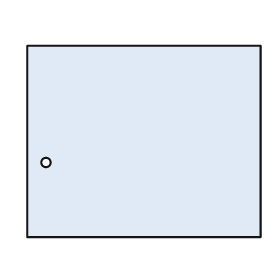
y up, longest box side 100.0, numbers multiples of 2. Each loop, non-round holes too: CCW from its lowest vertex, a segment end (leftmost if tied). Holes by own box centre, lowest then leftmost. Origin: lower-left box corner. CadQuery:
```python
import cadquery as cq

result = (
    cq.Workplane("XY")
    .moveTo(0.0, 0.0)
    .lineTo(100.0, 0.0)
    .lineTo(100.0, 82.0)
    .lineTo(0.0, 82.0)
    .close()
    .moveTo(8.0, 32.0)
    .circle(2.0)
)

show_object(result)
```